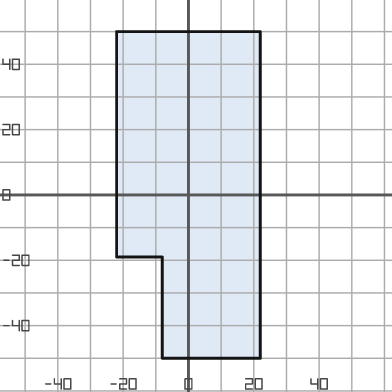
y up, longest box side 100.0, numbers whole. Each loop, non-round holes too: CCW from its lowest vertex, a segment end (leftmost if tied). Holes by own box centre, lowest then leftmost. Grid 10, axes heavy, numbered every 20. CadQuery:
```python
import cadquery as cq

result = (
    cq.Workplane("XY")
    .moveTo(-8.0, -50.0)
    .lineTo(22.0, -50.0)
    .lineTo(22.0, 50.0)
    .lineTo(-22.0, 50.0)
    .lineTo(-22.0, -19.0)
    .lineTo(-8.0, -19.0)
    .close()
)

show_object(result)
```